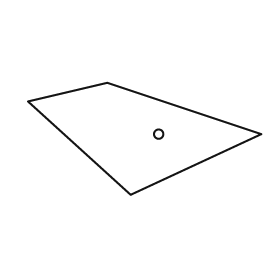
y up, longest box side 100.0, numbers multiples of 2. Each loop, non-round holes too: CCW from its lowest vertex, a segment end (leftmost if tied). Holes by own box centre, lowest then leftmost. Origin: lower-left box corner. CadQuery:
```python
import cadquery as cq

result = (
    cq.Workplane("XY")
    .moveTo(44.0, 0.0)
    .lineTo(100.0, 26.0)
    .lineTo(34.0, 48.0)
    .lineTo(0.0, 40.0)
    .close()
    .moveTo(56.0, 26.0)
    .circle(2.0)
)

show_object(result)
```